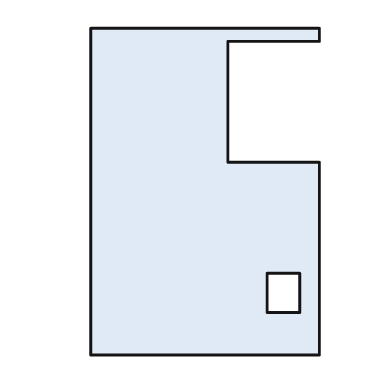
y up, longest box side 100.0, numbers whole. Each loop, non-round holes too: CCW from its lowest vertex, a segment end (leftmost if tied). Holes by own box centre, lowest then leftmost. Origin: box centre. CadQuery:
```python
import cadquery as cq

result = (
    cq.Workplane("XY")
    .moveTo(-35.0, -50.0)
    .lineTo(35.0, -50.0)
    .lineTo(35.0, 9.0)
    .lineTo(7.0, 9.0)
    .lineTo(7.0, 46.0)
    .lineTo(35.0, 46.0)
    .lineTo(35.0, 50.0)
    .lineTo(-35.0, 50.0)
    .close()
    .moveTo(19.0, -37.0)
    .lineTo(29.0, -37.0)
    .lineTo(29.0, -25.0)
    .lineTo(19.0, -25.0)
    .close()
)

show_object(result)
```